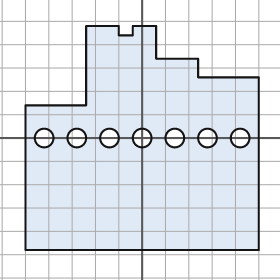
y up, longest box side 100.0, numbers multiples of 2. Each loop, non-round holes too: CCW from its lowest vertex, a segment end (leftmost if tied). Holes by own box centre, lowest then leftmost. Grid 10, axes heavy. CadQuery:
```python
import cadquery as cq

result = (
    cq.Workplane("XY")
    .moveTo(-50.0, -48.0)
    .lineTo(50.0, -48.0)
    .lineTo(50.0, 26.0)
    .lineTo(24.0, 26.0)
    .lineTo(24.0, 34.0)
    .lineTo(6.0, 34.0)
    .lineTo(6.0, 48.0)
    .lineTo(-4.0, 48.0)
    .lineTo(-4.0, 44.0)
    .lineTo(-10.0, 44.0)
    .lineTo(-10.0, 48.0)
    .lineTo(-24.0, 48.0)
    .lineTo(-24.0, 14.0)
    .lineTo(-50.0, 14.0)
    .close()
    .moveTo(-42.0, 0.0)
    .circle(4.0)
    .moveTo(-28.0, 0.0)
    .circle(4.0)
    .moveTo(-14.0, 0.0)
    .circle(4.0)
    .moveTo(0.0, 0.0)
    .circle(4.0)
    .moveTo(14.0, 0.0)
    .circle(4.0)
    .moveTo(28.0, 0.0)
    .circle(4.0)
    .moveTo(42.0, 0.0)
    .circle(4.0)
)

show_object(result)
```